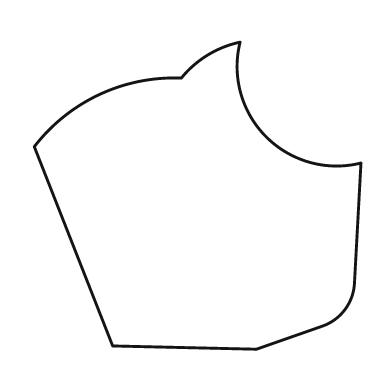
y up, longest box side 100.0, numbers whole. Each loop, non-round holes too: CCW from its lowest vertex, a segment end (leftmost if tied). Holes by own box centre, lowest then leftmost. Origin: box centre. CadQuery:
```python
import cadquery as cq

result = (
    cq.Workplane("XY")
    .moveTo(18.0, -47.0)
    .lineTo(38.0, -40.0)
    .threePointArc((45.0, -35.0), (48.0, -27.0))
    .lineTo(50.0, 10.0)
    .threePointArc((21.0, 18.0), (13.0, 47.0))
    .threePointArc((3.0, 43.0), (-5.0, 36.0))
    .threePointArc((-30.0, 31.0), (-50.0, 15.0))
    .lineTo(-26.0, -46.0)
    .close()
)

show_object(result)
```